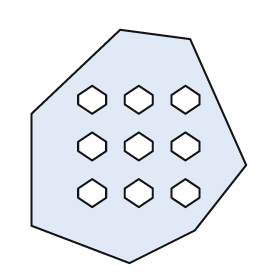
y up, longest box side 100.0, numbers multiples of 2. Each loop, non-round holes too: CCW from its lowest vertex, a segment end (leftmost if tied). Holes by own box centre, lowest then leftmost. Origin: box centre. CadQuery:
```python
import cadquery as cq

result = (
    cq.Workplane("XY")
    .moveTo(-4.0, -50.0)
    .lineTo(24.0, -36.0)
    .lineTo(46.0, -8.0)
    .lineTo(22.0, 46.0)
    .lineTo(-8.0, 50.0)
    .lineTo(-46.0, 14.0)
    .lineTo(-46.0, -34.0)
    .close()
    .moveTo(-20.0, -26.0)
    .lineTo(-14.0, -22.0)
    .lineTo(-14.0, -18.0)
    .lineTo(-20.0, -14.0)
    .lineTo(-26.0, -18.0)
    .lineTo(-26.0, -22.0)
    .close()
    .moveTo(0.0, -26.0)
    .lineTo(6.0, -22.0)
    .lineTo(6.0, -18.0)
    .lineTo(0.0, -14.0)
    .lineTo(-6.0, -18.0)
    .lineTo(-6.0, -22.0)
    .close()
    .moveTo(20.0, -26.0)
    .lineTo(26.0, -22.0)
    .lineTo(26.0, -18.0)
    .lineTo(20.0, -14.0)
    .lineTo(14.0, -18.0)
    .lineTo(14.0, -22.0)
    .close()
    .moveTo(-20.0, -6.0)
    .lineTo(-14.0, -2.0)
    .lineTo(-14.0, 2.0)
    .lineTo(-20.0, 6.0)
    .lineTo(-26.0, 2.0)
    .lineTo(-26.0, -2.0)
    .close()
    .moveTo(0.0, -6.0)
    .lineTo(6.0, -2.0)
    .lineTo(6.0, 2.0)
    .lineTo(0.0, 6.0)
    .lineTo(-6.0, 2.0)
    .lineTo(-6.0, -2.0)
    .close()
    .moveTo(20.0, -6.0)
    .lineTo(26.0, -2.0)
    .lineTo(26.0, 2.0)
    .lineTo(20.0, 6.0)
    .lineTo(14.0, 2.0)
    .lineTo(14.0, -2.0)
    .close()
    .moveTo(-20.0, 14.0)
    .lineTo(-14.0, 18.0)
    .lineTo(-14.0, 22.0)
    .lineTo(-20.0, 26.0)
    .lineTo(-26.0, 22.0)
    .lineTo(-26.0, 18.0)
    .close()
    .moveTo(0.0, 14.0)
    .lineTo(6.0, 18.0)
    .lineTo(6.0, 22.0)
    .lineTo(0.0, 26.0)
    .lineTo(-6.0, 22.0)
    .lineTo(-6.0, 18.0)
    .close()
    .moveTo(20.0, 14.0)
    .lineTo(26.0, 18.0)
    .lineTo(26.0, 22.0)
    .lineTo(20.0, 26.0)
    .lineTo(14.0, 22.0)
    .lineTo(14.0, 18.0)
    .close()
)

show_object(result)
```